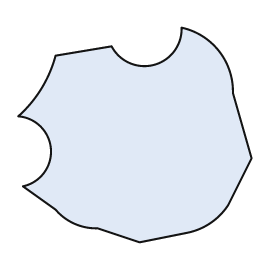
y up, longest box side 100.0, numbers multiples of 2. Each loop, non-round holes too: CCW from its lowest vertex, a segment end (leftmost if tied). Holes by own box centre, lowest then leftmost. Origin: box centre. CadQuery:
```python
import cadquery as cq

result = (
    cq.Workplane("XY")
    .moveTo(2.0, -46.0)
    .lineTo(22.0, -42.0)
    .threePointArc((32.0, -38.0), (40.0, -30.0))
    .lineTo(50.0, -10.0)
    .lineTo(42.0, 18.0)
    .threePointArc((36.0, 36.0), (20.0, 46.0))
    .threePointArc((8.0, 30.0), (-10.0, 38.0))
    .lineTo(-34.0, 34.0)
    .threePointArc((-40.0, 20.0), (-50.0, 8.0))
    .threePointArc((-36.0, -6.0), (-48.0, -22.0))
    .lineTo(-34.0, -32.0)
    .threePointArc((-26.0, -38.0), (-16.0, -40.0))
    .close()
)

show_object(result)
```